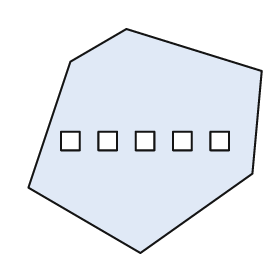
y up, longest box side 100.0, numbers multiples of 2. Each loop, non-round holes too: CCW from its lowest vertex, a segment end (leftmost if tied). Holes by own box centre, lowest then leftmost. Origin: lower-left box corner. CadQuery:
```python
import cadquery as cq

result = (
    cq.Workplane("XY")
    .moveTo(48.0, 0.0)
    .lineTo(96.0, 34.0)
    .lineTo(100.0, 78.0)
    .lineTo(42.0, 96.0)
    .lineTo(18.0, 82.0)
    .lineTo(0.0, 28.0)
    .close()
    .moveTo(14.0, 44.0)
    .lineTo(22.0, 44.0)
    .lineTo(22.0, 52.0)
    .lineTo(14.0, 52.0)
    .close()
    .moveTo(30.0, 44.0)
    .lineTo(38.0, 44.0)
    .lineTo(38.0, 52.0)
    .lineTo(30.0, 52.0)
    .close()
    .moveTo(46.0, 44.0)
    .lineTo(54.0, 44.0)
    .lineTo(54.0, 52.0)
    .lineTo(46.0, 52.0)
    .close()
    .moveTo(62.0, 44.0)
    .lineTo(70.0, 44.0)
    .lineTo(70.0, 52.0)
    .lineTo(62.0, 52.0)
    .close()
    .moveTo(78.0, 44.0)
    .lineTo(86.0, 44.0)
    .lineTo(86.0, 52.0)
    .lineTo(78.0, 52.0)
    .close()
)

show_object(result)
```